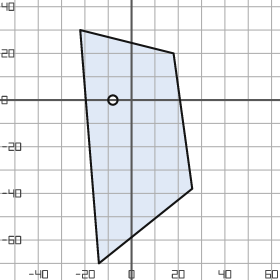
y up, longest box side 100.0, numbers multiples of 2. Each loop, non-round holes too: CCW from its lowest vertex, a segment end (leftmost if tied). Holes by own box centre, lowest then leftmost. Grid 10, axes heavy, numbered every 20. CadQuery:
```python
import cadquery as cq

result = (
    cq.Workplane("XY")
    .moveTo(-14.0, -70.0)
    .lineTo(26.0, -38.0)
    .lineTo(18.0, 20.0)
    .lineTo(-22.0, 30.0)
    .close()
    .moveTo(-8.0, 0.0)
    .circle(2.0)
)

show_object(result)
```